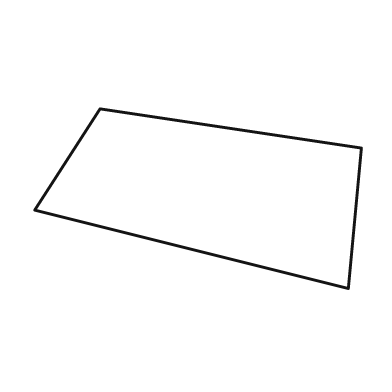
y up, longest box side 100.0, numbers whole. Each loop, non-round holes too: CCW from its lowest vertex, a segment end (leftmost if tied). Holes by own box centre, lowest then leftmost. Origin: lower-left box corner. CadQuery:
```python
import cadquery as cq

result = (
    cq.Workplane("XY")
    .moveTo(96.0, 0.0)
    .lineTo(100.0, 43.0)
    .lineTo(20.0, 55.0)
    .lineTo(0.0, 24.0)
    .close()
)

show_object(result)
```